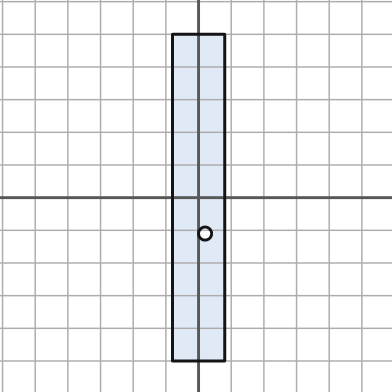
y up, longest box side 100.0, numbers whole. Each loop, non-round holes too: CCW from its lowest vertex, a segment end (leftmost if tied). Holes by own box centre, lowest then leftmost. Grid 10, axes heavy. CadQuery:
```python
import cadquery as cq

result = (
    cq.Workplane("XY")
    .moveTo(-8.0, -50.0)
    .lineTo(8.0, -50.0)
    .lineTo(8.0, 50.0)
    .lineTo(-8.0, 50.0)
    .close()
    .moveTo(2.0, -11.0)
    .circle(2.0)
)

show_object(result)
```